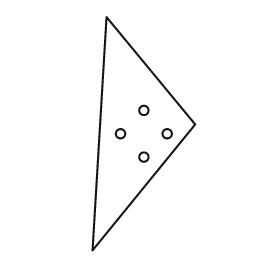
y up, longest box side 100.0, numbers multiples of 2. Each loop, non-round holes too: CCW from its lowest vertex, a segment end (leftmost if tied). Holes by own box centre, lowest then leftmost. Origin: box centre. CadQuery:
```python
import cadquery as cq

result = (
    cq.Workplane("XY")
    .moveTo(-22.0, -50.0)
    .lineTo(22.0, 4.0)
    .lineTo(-16.0, 50.0)
    .close()
    .moveTo(0.0, -10.0)
    .circle(2.0)
    .moveTo(-10.0, 0.0)
    .circle(2.0)
    .moveTo(10.0, 0.0)
    .circle(2.0)
    .moveTo(0.0, 10.0)
    .circle(2.0)
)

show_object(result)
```